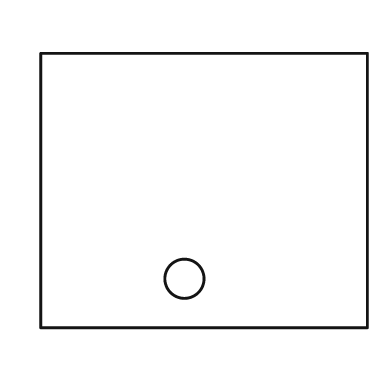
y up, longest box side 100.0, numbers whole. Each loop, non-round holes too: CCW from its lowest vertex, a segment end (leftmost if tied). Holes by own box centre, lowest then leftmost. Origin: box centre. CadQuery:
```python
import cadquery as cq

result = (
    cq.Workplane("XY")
    .moveTo(-50.0, -42.0)
    .lineTo(50.0, -42.0)
    .lineTo(50.0, 42.0)
    .lineTo(-50.0, 42.0)
    .close()
    .moveTo(-6.0, -27.0)
    .circle(6.0)
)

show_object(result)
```